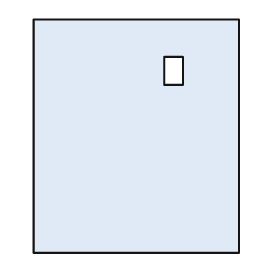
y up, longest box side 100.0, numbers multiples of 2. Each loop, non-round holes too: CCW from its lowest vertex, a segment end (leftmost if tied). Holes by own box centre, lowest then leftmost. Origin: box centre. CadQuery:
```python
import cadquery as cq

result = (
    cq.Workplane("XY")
    .moveTo(-44.0, -50.0)
    .lineTo(44.0, -50.0)
    .lineTo(44.0, 50.0)
    .lineTo(-44.0, 50.0)
    .close()
    .moveTo(12.0, 22.0)
    .lineTo(20.0, 22.0)
    .lineTo(20.0, 34.0)
    .lineTo(12.0, 34.0)
    .close()
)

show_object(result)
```